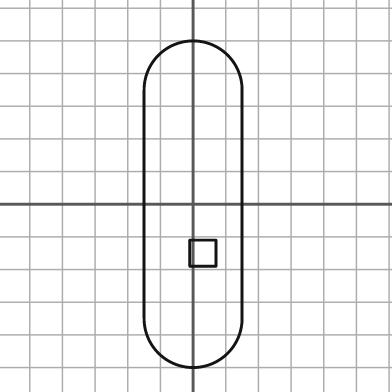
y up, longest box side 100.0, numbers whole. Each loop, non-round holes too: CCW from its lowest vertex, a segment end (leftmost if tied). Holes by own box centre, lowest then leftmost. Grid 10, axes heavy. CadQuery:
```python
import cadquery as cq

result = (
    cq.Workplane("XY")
    .moveTo(-15.0, -35.0)
    .threePointArc((0.0, -50.0), (15.0, -35.0))
    .lineTo(15.0, 35.0)
    .threePointArc((0.0, 50.0), (-15.0, 35.0))
    .close()
    .moveTo(-1.0, -19.0)
    .lineTo(7.0, -19.0)
    .lineTo(7.0, -11.0)
    .lineTo(-1.0, -11.0)
    .close()
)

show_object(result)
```